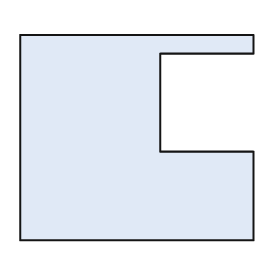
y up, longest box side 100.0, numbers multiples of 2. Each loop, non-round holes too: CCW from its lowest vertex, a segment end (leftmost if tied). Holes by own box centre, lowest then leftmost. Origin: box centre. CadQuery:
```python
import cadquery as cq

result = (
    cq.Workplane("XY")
    .moveTo(-50.0, -44.0)
    .lineTo(50.0, -44.0)
    .lineTo(50.0, -6.0)
    .lineTo(10.0, -6.0)
    .lineTo(10.0, 36.0)
    .lineTo(50.0, 36.0)
    .lineTo(50.0, 44.0)
    .lineTo(-50.0, 44.0)
    .close()
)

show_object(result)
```